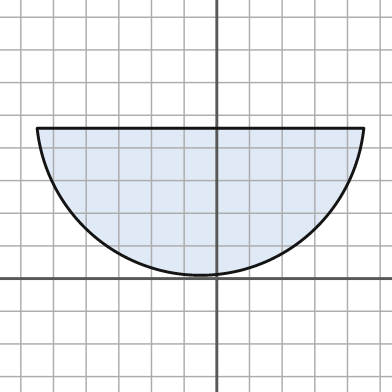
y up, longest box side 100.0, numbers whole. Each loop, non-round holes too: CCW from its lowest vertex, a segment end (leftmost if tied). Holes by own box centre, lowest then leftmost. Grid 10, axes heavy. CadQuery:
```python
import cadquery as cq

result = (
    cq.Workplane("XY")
    .moveTo(-55.0, 46.0)
    .threePointArc((-5.0, 1.0), (45.0, 46.0))
    .close()
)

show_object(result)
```